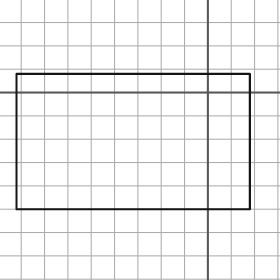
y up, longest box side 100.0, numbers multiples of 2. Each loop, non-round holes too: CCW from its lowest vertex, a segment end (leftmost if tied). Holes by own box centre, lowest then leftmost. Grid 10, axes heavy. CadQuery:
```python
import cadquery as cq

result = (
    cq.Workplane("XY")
    .moveTo(-82.0, -50.0)
    .lineTo(18.0, -50.0)
    .lineTo(18.0, 8.0)
    .lineTo(-82.0, 8.0)
    .close()
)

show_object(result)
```